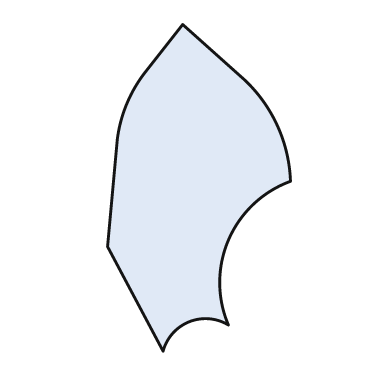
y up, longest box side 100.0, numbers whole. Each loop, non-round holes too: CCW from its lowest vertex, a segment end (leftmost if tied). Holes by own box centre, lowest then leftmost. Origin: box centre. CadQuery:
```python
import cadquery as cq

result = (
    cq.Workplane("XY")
    .moveTo(-11.0, -50.0)
    .threePointArc((-3.0, -41.0), (9.0, -42.0))
    .threePointArc((9.0, -16.0), (28.0, 2.0))
    .threePointArc((24.0, 19.0), (14.0, 33.0))
    .lineTo(-5.0, 50.0)
    .lineTo(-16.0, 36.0)
    .threePointArc((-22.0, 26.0), (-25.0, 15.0))
    .lineTo(-28.0, -18.0)
    .close()
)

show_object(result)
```